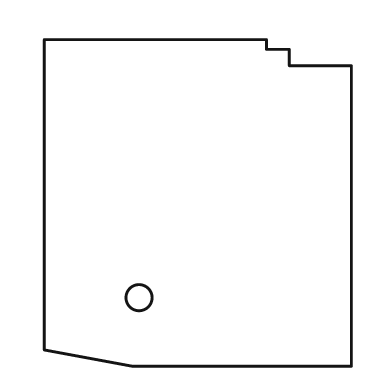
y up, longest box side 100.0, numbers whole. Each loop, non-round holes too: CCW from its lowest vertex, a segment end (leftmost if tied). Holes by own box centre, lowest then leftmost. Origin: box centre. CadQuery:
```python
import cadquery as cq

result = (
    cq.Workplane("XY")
    .moveTo(-20.0, -50.0)
    .lineTo(47.0, -50.0)
    .lineTo(47.0, 42.0)
    .lineTo(28.0, 42.0)
    .lineTo(28.0, 47.0)
    .lineTo(21.0, 47.0)
    .lineTo(21.0, 50.0)
    .lineTo(-47.0, 50.0)
    .lineTo(-47.0, -45.0)
    .close()
    .moveTo(-18.0, -29.0)
    .circle(4.0)
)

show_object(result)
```